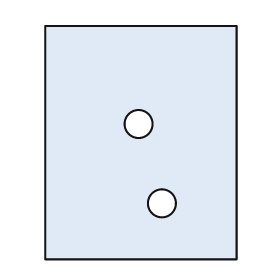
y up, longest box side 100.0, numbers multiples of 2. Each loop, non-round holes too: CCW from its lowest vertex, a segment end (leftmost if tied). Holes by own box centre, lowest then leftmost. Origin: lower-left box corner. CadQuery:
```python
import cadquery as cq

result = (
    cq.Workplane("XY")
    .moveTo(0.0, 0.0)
    .lineTo(82.0, 0.0)
    .lineTo(82.0, 100.0)
    .lineTo(0.0, 100.0)
    .close()
    .moveTo(50.0, 24.0)
    .circle(6.0)
    .moveTo(40.0, 58.0)
    .circle(6.0)
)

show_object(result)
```